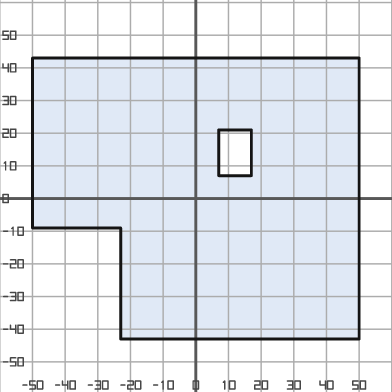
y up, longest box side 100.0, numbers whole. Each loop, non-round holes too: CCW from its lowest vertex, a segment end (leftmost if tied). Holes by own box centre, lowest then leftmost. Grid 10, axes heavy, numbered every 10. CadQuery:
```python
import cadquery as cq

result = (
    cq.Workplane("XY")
    .moveTo(-23.0, -43.0)
    .lineTo(50.0, -43.0)
    .lineTo(50.0, 43.0)
    .lineTo(-50.0, 43.0)
    .lineTo(-50.0, -9.0)
    .lineTo(-23.0, -9.0)
    .close()
    .moveTo(7.0, 7.0)
    .lineTo(17.0, 7.0)
    .lineTo(17.0, 21.0)
    .lineTo(7.0, 21.0)
    .close()
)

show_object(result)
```